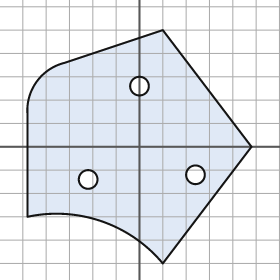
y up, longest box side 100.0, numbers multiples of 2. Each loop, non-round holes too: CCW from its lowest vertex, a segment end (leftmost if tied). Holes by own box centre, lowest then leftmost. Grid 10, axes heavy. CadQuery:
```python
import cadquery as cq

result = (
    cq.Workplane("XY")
    .moveTo(10.0, -50.0)
    .lineTo(48.0, 0.0)
    .lineTo(10.0, 50.0)
    .lineTo(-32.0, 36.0)
    .threePointArc((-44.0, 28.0), (-48.0, 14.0))
    .lineTo(-48.0, -30.0)
    .threePointArc((-16.0, -32.0), (10.0, -50.0))
    .close()
    .moveTo(-22.0, -14.0)
    .circle(4.0)
    .moveTo(24.0, -12.0)
    .circle(4.0)
    .moveTo(0.0, 26.0)
    .circle(4.0)
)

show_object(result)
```